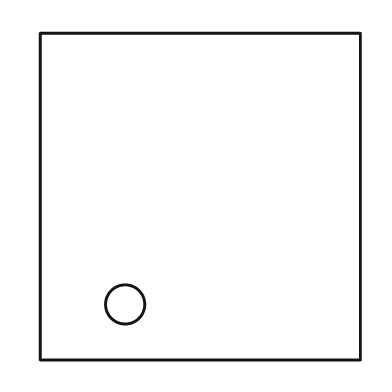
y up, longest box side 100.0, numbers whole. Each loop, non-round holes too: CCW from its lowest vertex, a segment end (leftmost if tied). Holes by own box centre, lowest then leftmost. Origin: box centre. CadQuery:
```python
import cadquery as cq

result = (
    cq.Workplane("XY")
    .moveTo(-49.0, -50.0)
    .lineTo(49.0, -50.0)
    .lineTo(49.0, 50.0)
    .lineTo(-49.0, 50.0)
    .close()
    .moveTo(-23.0, -33.0)
    .circle(6.0)
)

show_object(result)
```